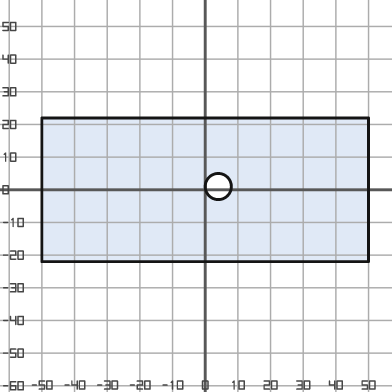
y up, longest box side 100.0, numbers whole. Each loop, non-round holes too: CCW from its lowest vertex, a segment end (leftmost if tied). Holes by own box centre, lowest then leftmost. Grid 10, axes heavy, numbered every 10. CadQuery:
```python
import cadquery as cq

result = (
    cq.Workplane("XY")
    .moveTo(-50.0, -22.0)
    .lineTo(50.0, -22.0)
    .lineTo(50.0, 22.0)
    .lineTo(-50.0, 22.0)
    .close()
    .moveTo(4.0, 1.0)
    .circle(4.0)
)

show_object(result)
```